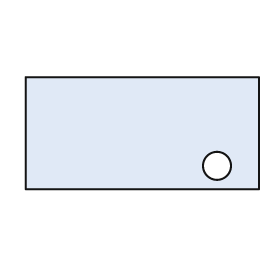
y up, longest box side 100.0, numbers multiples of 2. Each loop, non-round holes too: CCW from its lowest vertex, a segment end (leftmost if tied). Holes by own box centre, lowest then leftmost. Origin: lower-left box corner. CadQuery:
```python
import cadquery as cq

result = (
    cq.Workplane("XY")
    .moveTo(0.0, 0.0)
    .lineTo(100.0, 0.0)
    .lineTo(100.0, 48.0)
    .lineTo(0.0, 48.0)
    .close()
    .moveTo(82.0, 10.0)
    .circle(6.0)
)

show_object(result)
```